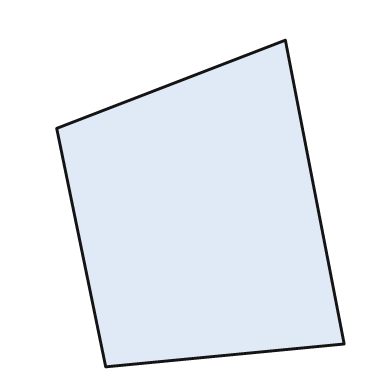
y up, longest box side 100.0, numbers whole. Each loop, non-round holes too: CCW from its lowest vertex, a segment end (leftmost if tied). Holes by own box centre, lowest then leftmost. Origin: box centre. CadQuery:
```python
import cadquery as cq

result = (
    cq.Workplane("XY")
    .moveTo(-29.0, -50.0)
    .lineTo(44.0, -43.0)
    .lineTo(26.0, 50.0)
    .lineTo(-44.0, 23.0)
    .close()
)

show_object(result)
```